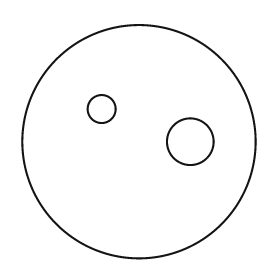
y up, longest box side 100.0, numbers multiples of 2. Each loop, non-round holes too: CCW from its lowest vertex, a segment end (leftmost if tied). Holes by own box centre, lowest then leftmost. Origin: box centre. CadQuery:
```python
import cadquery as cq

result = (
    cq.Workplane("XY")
    .moveTo(0.0, 0.0)
    .circle(50.0)
    .moveTo(22.0, 0.0)
    .circle(10.0)
    .moveTo(-16.0, 14.0)
    .circle(6.0)
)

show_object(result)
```